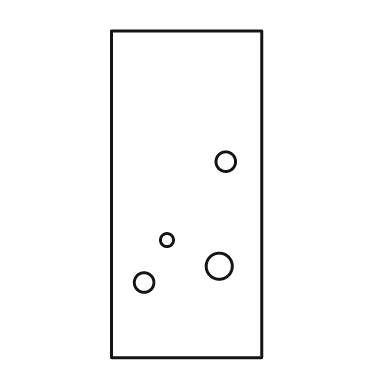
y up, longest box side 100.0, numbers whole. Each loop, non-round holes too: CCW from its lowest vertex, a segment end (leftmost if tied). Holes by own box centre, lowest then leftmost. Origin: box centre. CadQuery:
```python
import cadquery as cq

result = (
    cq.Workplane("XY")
    .moveTo(-23.0, -50.0)
    .lineTo(23.0, -50.0)
    .lineTo(23.0, 50.0)
    .lineTo(-23.0, 50.0)
    .close()
    .moveTo(-13.0, -27.0)
    .circle(3.0)
    .moveTo(10.0, -22.0)
    .circle(4.0)
    .moveTo(-6.0, -14.0)
    .circle(2.0)
    .moveTo(12.0, 10.0)
    .circle(3.0)
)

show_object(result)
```